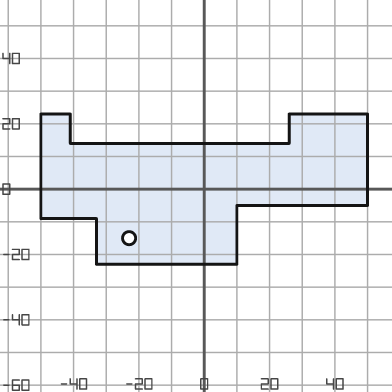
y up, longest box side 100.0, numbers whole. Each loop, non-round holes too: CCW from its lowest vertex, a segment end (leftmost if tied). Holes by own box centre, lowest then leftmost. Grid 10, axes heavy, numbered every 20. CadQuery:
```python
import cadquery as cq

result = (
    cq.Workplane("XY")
    .moveTo(-33.0, -23.0)
    .lineTo(10.0, -23.0)
    .lineTo(10.0, -5.0)
    .lineTo(50.0, -5.0)
    .lineTo(50.0, 23.0)
    .lineTo(26.0, 23.0)
    .lineTo(26.0, 14.0)
    .lineTo(-41.0, 14.0)
    .lineTo(-41.0, 23.0)
    .lineTo(-50.0, 23.0)
    .lineTo(-50.0, -9.0)
    .lineTo(-33.0, -9.0)
    .close()
    .moveTo(-23.0, -15.0)
    .circle(2.0)
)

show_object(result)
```